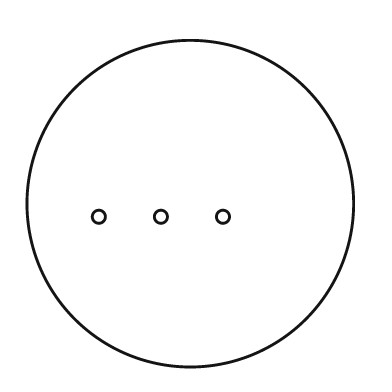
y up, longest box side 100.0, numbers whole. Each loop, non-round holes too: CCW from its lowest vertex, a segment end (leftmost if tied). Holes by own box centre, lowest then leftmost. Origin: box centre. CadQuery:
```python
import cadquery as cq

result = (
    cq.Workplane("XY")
    .moveTo(0.0, 0.0)
    .circle(50.0)
    .moveTo(-28.0, -4.0)
    .circle(2.0)
    .moveTo(-9.0, -4.0)
    .circle(2.0)
    .moveTo(10.0, -4.0)
    .circle(2.0)
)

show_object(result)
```